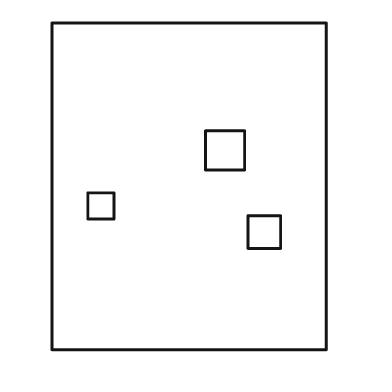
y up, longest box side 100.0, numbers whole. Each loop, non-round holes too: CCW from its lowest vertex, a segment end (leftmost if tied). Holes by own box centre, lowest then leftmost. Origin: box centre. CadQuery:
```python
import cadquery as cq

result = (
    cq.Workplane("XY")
    .moveTo(-42.0, -50.0)
    .lineTo(42.0, -50.0)
    .lineTo(42.0, 50.0)
    .lineTo(-42.0, 50.0)
    .close()
    .moveTo(18.0, -19.0)
    .lineTo(28.0, -19.0)
    .lineTo(28.0, -9.0)
    .lineTo(18.0, -9.0)
    .close()
    .moveTo(-31.0, -10.0)
    .lineTo(-23.0, -10.0)
    .lineTo(-23.0, -2.0)
    .lineTo(-31.0, -2.0)
    .close()
    .moveTo(5.0, 5.0)
    .lineTo(17.0, 5.0)
    .lineTo(17.0, 17.0)
    .lineTo(5.0, 17.0)
    .close()
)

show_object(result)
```